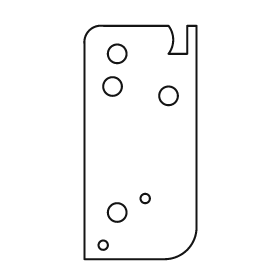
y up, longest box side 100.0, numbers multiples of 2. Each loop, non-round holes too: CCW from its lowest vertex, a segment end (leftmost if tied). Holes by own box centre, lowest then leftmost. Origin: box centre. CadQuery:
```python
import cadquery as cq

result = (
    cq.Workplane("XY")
    .moveTo(-24.0, -50.0)
    .lineTo(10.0, -50.0)
    .threePointArc((20.0, -46.0), (24.0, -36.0))
    .lineTo(24.0, 50.0)
    .lineTo(20.0, 50.0)
    .lineTo(20.0, 38.0)
    .lineTo(12.0, 38.0)
    .threePointArc((14.0, 44.0), (12.0, 50.0))
    .lineTo(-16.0, 50.0)
    .threePointArc((-22.0, 48.0), (-24.0, 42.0))
    .close()
    .moveTo(-16.0, -44.0)
    .circle(2.0)
    .moveTo(-10.0, -30.0)
    .circle(4.0)
    .moveTo(2.0, -24.0)
    .circle(2.0)
    .moveTo(12.0, 20.0)
    .circle(4.0)
    .moveTo(-12.0, 24.0)
    .circle(4.0)
    .moveTo(-10.0, 38.0)
    .circle(4.0)
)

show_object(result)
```